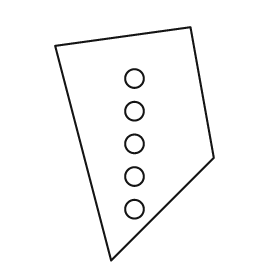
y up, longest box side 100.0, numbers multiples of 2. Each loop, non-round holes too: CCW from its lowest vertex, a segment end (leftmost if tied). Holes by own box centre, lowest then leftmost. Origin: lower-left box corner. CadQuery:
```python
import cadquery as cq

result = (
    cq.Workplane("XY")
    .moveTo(24.0, 0.0)
    .lineTo(68.0, 44.0)
    .lineTo(58.0, 100.0)
    .lineTo(0.0, 92.0)
    .close()
    .moveTo(34.0, 22.0)
    .circle(4.0)
    .moveTo(34.0, 36.0)
    .circle(4.0)
    .moveTo(34.0, 50.0)
    .circle(4.0)
    .moveTo(34.0, 64.0)
    .circle(4.0)
    .moveTo(34.0, 78.0)
    .circle(4.0)
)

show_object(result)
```